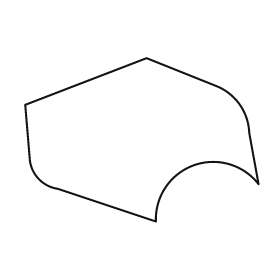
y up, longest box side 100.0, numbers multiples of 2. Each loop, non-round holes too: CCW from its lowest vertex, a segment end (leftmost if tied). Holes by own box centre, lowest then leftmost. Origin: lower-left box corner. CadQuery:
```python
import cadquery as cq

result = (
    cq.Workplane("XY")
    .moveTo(56.0, 0.0)
    .threePointArc((72.0, 24.0), (100.0, 16.0))
    .lineTo(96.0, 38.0)
    .threePointArc((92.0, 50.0), (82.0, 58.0))
    .lineTo(52.0, 70.0)
    .lineTo(0.0, 50.0)
    .lineTo(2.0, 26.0)
    .threePointArc((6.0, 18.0), (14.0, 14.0))
    .close()
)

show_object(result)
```